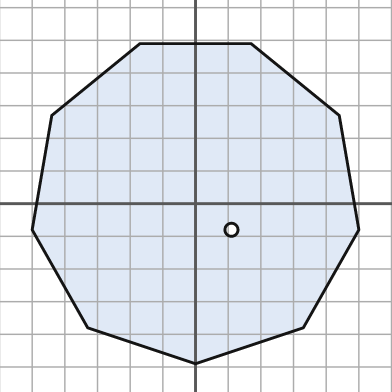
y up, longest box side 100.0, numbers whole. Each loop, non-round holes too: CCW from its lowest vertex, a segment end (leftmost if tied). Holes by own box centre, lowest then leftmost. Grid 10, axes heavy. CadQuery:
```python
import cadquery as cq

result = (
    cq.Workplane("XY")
    .moveTo(0.0, -49.0)
    .lineTo(33.0, -38.0)
    .lineTo(50.0, -8.0)
    .lineTo(44.0, 27.0)
    .lineTo(17.0, 49.0)
    .lineTo(-17.0, 49.0)
    .lineTo(-44.0, 27.0)
    .lineTo(-50.0, -8.0)
    .lineTo(-33.0, -38.0)
    .close()
    .moveTo(11.0, -8.0)
    .circle(2.0)
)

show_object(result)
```